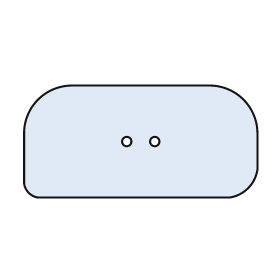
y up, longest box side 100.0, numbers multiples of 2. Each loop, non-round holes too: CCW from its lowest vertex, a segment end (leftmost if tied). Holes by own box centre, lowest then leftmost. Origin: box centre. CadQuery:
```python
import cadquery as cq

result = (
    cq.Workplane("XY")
    .moveTo(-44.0, -24.0)
    .lineTo(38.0, -24.0)
    .threePointArc((46.0, -20.0), (50.0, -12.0))
    .lineTo(50.0, 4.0)
    .threePointArc((44.0, 18.0), (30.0, 24.0))
    .lineTo(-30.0, 24.0)
    .threePointArc((-44.0, 18.0), (-50.0, 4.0))
    .lineTo(-50.0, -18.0)
    .threePointArc((-48.0, -22.0), (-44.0, -24.0))
    .close()
    .moveTo(-6.0, 0.0)
    .circle(2.0)
    .moveTo(6.0, 0.0)
    .circle(2.0)
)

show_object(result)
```